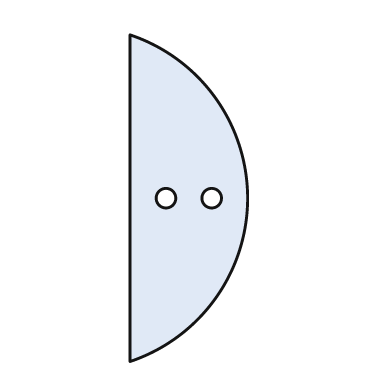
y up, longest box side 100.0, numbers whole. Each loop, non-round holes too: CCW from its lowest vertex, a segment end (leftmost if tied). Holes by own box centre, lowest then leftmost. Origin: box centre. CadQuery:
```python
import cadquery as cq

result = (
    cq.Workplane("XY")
    .moveTo(-18.0, -50.0)
    .threePointArc((18.0, 0.0), (-18.0, 50.0))
    .close()
    .moveTo(-7.0, 0.0)
    .circle(3.0)
    .moveTo(7.0, 0.0)
    .circle(3.0)
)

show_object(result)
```